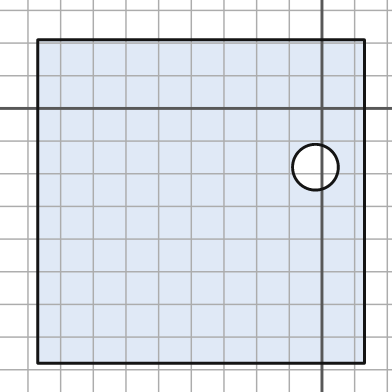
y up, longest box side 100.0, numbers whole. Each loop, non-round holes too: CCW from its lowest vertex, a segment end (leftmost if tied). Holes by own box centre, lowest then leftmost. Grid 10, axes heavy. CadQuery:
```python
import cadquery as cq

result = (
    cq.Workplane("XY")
    .moveTo(-87.0, -78.0)
    .lineTo(13.0, -78.0)
    .lineTo(13.0, 21.0)
    .lineTo(-87.0, 21.0)
    .close()
    .moveTo(-2.0, -18.0)
    .circle(7.0)
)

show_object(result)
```